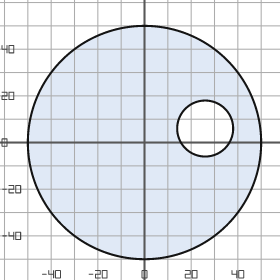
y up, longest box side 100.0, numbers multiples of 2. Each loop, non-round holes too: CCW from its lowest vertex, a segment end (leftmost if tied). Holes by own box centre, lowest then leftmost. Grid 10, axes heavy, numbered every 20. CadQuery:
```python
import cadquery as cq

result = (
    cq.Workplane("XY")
    .moveTo(0.0, 0.0)
    .circle(50.0)
    .moveTo(26.0, 6.0)
    .circle(12.0)
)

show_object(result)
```